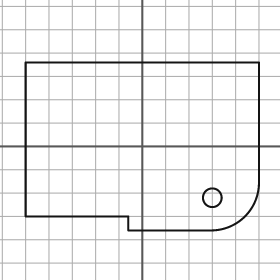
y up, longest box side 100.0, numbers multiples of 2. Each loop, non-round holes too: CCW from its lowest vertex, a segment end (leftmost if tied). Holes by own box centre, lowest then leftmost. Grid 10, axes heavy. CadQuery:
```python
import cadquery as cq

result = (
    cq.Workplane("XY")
    .moveTo(-6.0, -36.0)
    .lineTo(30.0, -36.0)
    .threePointArc((44.0, -30.0), (50.0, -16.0))
    .lineTo(50.0, 36.0)
    .lineTo(-50.0, 36.0)
    .lineTo(-50.0, -30.0)
    .lineTo(-6.0, -30.0)
    .close()
    .moveTo(30.0, -22.0)
    .circle(4.0)
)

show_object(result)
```